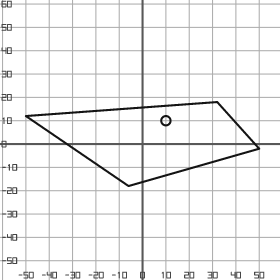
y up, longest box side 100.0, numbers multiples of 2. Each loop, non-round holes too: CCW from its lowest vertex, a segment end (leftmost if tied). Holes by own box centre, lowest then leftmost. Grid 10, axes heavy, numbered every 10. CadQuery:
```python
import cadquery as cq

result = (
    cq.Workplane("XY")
    .moveTo(-6.0, -18.0)
    .lineTo(50.0, -2.0)
    .lineTo(32.0, 18.0)
    .lineTo(-50.0, 12.0)
    .close()
    .moveTo(10.0, 10.0)
    .circle(2.0)
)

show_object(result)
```